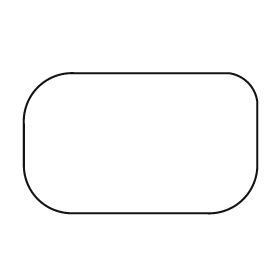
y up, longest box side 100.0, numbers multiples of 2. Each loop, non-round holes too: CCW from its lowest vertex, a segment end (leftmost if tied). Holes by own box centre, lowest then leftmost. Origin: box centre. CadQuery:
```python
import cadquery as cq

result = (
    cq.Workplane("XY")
    .moveTo(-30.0, -30.0)
    .lineTo(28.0, -30.0)
    .threePointArc((44.0, -24.0), (50.0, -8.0))
    .lineTo(50.0, 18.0)
    .threePointArc((46.0, 26.0), (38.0, 30.0))
    .lineTo(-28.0, 30.0)
    .threePointArc((-44.0, 24.0), (-50.0, 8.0))
    .lineTo(-50.0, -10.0)
    .threePointArc((-44.0, -24.0), (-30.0, -30.0))
    .close()
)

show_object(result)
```